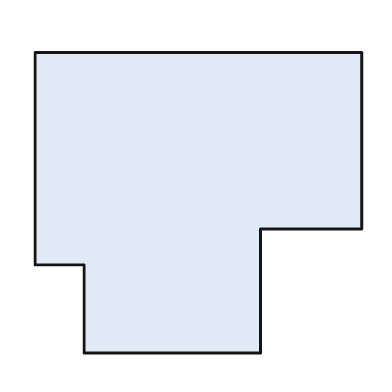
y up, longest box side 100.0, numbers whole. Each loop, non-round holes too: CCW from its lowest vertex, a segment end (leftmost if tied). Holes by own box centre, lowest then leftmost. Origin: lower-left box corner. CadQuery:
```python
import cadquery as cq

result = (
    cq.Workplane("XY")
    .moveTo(15.0, 0.0)
    .lineTo(69.0, 0.0)
    .lineTo(69.0, 38.0)
    .lineTo(100.0, 38.0)
    .lineTo(100.0, 92.0)
    .lineTo(0.0, 92.0)
    .lineTo(0.0, 27.0)
    .lineTo(15.0, 27.0)
    .close()
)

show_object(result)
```